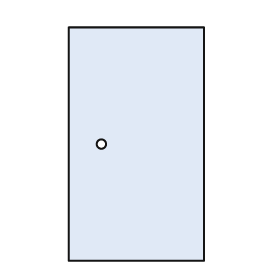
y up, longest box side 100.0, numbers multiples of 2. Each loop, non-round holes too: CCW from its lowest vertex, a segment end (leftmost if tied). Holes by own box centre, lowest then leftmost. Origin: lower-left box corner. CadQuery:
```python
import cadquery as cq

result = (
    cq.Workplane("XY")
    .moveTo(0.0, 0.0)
    .lineTo(58.0, 0.0)
    .lineTo(58.0, 100.0)
    .lineTo(0.0, 100.0)
    .close()
    .moveTo(14.0, 50.0)
    .circle(2.0)
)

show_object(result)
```